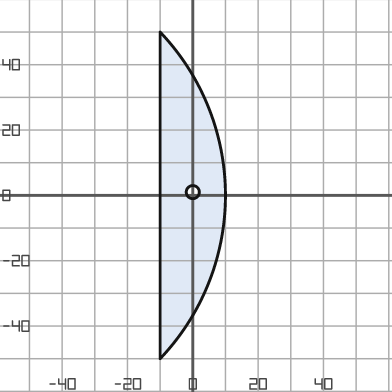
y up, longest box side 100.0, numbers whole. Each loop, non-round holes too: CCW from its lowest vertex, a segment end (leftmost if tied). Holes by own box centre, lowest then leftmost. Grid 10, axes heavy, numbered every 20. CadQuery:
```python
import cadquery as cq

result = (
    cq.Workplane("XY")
    .moveTo(-10.0, -50.0)
    .threePointArc((10.0, 0.0), (-10.0, 50.0))
    .close()
    .moveTo(0.0, 1.0)
    .circle(2.0)
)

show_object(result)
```